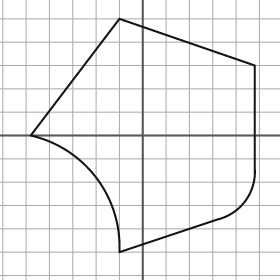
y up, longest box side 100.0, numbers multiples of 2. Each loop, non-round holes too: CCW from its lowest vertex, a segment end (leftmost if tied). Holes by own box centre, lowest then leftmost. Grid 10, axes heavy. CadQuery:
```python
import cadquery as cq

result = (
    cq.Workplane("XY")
    .moveTo(-10.0, -50.0)
    .lineTo(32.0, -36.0)
    .threePointArc((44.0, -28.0), (48.0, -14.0))
    .lineTo(48.0, 30.0)
    .lineTo(-10.0, 50.0)
    .lineTo(-48.0, 0.0)
    .threePointArc((-20.0, -18.0), (-10.0, -50.0))
    .close()
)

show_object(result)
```